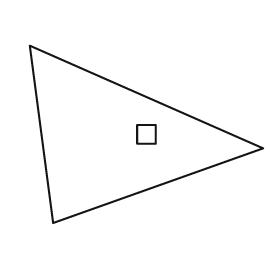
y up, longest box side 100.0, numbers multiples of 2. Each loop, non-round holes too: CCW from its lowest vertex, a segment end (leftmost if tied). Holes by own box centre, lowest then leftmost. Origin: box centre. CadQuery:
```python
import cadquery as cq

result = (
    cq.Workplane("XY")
    .moveTo(-40.0, -38.0)
    .lineTo(50.0, -6.0)
    .lineTo(-50.0, 38.0)
    .close()
    .moveTo(-4.0, -4.0)
    .lineTo(4.0, -4.0)
    .lineTo(4.0, 4.0)
    .lineTo(-4.0, 4.0)
    .close()
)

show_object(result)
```